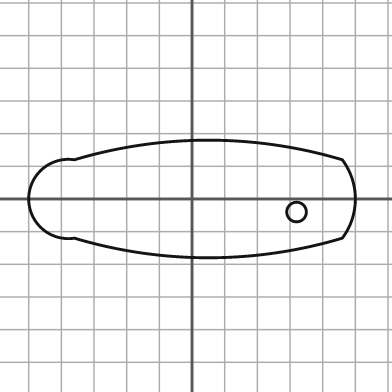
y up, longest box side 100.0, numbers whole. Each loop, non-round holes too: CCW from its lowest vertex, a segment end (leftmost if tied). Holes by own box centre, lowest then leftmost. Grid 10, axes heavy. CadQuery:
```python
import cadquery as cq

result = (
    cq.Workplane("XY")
    .moveTo(-36.0, -12.0)
    .threePointArc((5.0, -18.0), (46.0, -12.0))
    .threePointArc((50.0, 0.0), (46.0, 12.0))
    .threePointArc((5.0, 18.0), (-36.0, 12.0))
    .threePointArc((-50.0, 0.0), (-36.0, -12.0))
    .close()
    .moveTo(32.0, -4.0)
    .circle(3.0)
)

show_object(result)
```